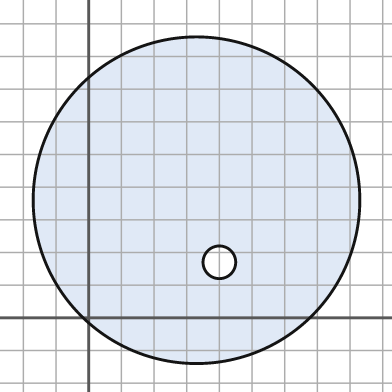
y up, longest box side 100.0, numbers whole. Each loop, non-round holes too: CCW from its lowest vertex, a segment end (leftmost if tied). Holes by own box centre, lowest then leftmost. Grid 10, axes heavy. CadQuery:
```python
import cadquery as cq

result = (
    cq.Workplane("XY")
    .moveTo(33.0, 36.0)
    .circle(50.0)
    .moveTo(40.0, 17.0)
    .circle(5.0)
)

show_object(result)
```